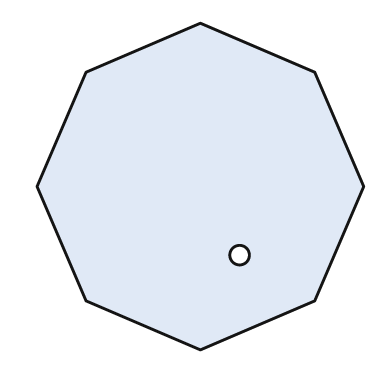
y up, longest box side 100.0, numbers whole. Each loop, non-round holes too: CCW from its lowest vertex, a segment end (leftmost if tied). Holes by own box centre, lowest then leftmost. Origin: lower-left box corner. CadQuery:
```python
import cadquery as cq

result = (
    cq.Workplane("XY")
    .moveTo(50.0, 0.0)
    .lineTo(85.0, 15.0)
    .lineTo(100.0, 50.0)
    .lineTo(85.0, 85.0)
    .lineTo(50.0, 100.0)
    .lineTo(15.0, 85.0)
    .lineTo(0.0, 50.0)
    .lineTo(15.0, 15.0)
    .close()
    .moveTo(62.0, 29.0)
    .circle(3.0)
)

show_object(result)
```